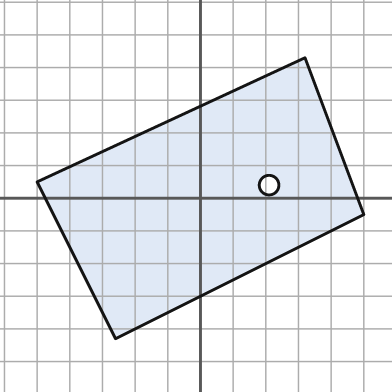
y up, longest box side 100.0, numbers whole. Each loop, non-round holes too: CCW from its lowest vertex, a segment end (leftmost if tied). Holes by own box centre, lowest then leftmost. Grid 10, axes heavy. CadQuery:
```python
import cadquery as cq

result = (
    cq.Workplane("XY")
    .moveTo(-26.0, -43.0)
    .lineTo(50.0, -5.0)
    .lineTo(32.0, 43.0)
    .lineTo(-50.0, 5.0)
    .close()
    .moveTo(21.0, 4.0)
    .circle(3.0)
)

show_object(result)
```